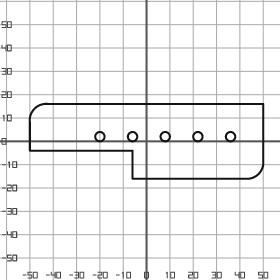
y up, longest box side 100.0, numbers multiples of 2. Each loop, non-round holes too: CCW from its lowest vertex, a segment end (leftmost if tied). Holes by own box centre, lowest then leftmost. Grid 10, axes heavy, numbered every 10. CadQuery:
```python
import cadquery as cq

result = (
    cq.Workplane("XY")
    .moveTo(-6.0, -16.0)
    .lineTo(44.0, -16.0)
    .threePointArc((48.0, -14.0), (50.0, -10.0))
    .lineTo(50.0, 16.0)
    .lineTo(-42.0, 16.0)
    .threePointArc((-48.0, 14.0), (-50.0, 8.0))
    .lineTo(-50.0, -4.0)
    .lineTo(-6.0, -4.0)
    .close()
    .moveTo(-20.0, 2.0)
    .circle(2.0)
    .moveTo(-6.0, 2.0)
    .circle(2.0)
    .moveTo(8.0, 2.0)
    .circle(2.0)
    .moveTo(22.0, 2.0)
    .circle(2.0)
    .moveTo(36.0, 2.0)
    .circle(2.0)
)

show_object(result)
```